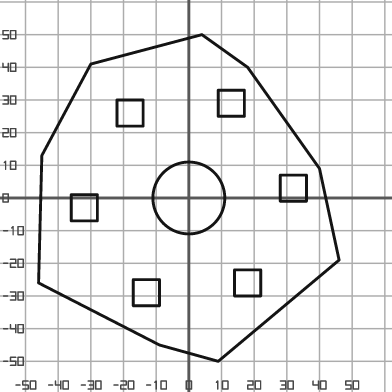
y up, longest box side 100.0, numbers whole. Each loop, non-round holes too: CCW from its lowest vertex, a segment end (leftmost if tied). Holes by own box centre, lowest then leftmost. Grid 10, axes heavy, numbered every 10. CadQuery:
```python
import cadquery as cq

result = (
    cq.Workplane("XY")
    .moveTo(9.0, -50.0)
    .lineTo(46.0, -19.0)
    .lineTo(40.0, 9.0)
    .lineTo(18.0, 40.0)
    .lineTo(4.0, 50.0)
    .lineTo(-30.0, 41.0)
    .lineTo(-45.0, 13.0)
    .lineTo(-46.0, -26.0)
    .lineTo(-9.0, -45.0)
    .close()
    .moveTo(-17.0, -33.0)
    .lineTo(-9.0, -33.0)
    .lineTo(-9.0, -25.0)
    .lineTo(-17.0, -25.0)
    .close()
    .moveTo(14.0, -30.0)
    .lineTo(22.0, -30.0)
    .lineTo(22.0, -22.0)
    .lineTo(14.0, -22.0)
    .close()
    .moveTo(-36.0, -7.0)
    .lineTo(-28.0, -7.0)
    .lineTo(-28.0, 1.0)
    .lineTo(-36.0, 1.0)
    .close()
    .moveTo(0.0, 0.0)
    .circle(11.0)
    .moveTo(28.0, -1.0)
    .lineTo(36.0, -1.0)
    .lineTo(36.0, 7.0)
    .lineTo(28.0, 7.0)
    .close()
    .moveTo(-22.0, 22.0)
    .lineTo(-14.0, 22.0)
    .lineTo(-14.0, 30.0)
    .lineTo(-22.0, 30.0)
    .close()
    .moveTo(9.0, 25.0)
    .lineTo(17.0, 25.0)
    .lineTo(17.0, 33.0)
    .lineTo(9.0, 33.0)
    .close()
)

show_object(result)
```